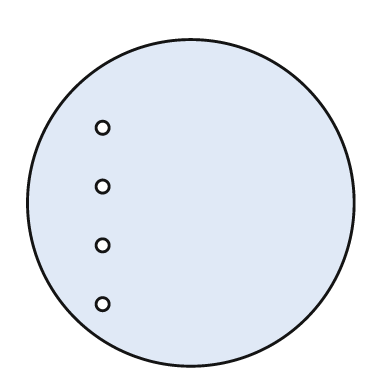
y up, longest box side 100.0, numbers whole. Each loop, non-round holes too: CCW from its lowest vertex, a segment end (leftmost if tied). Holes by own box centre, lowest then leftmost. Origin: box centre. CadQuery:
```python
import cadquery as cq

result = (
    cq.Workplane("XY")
    .moveTo(0.0, 0.0)
    .circle(50.0)
    .moveTo(-27.0, -31.0)
    .circle(2.0)
    .moveTo(-27.0, -13.0)
    .circle(2.0)
    .moveTo(-27.0, 5.0)
    .circle(2.0)
    .moveTo(-27.0, 23.0)
    .circle(2.0)
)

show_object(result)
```